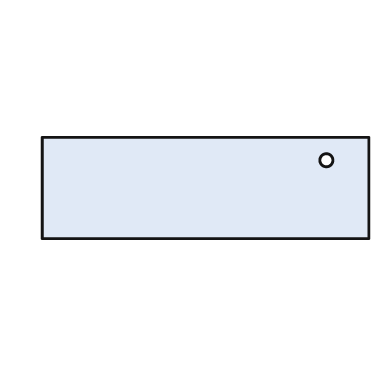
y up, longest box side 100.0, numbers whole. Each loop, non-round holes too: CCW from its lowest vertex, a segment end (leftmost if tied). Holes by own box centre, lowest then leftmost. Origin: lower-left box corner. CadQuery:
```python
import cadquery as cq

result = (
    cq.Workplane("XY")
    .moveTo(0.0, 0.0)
    .lineTo(100.0, 0.0)
    .lineTo(100.0, 31.0)
    .lineTo(0.0, 31.0)
    .close()
    .moveTo(87.0, 24.0)
    .circle(2.0)
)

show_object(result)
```